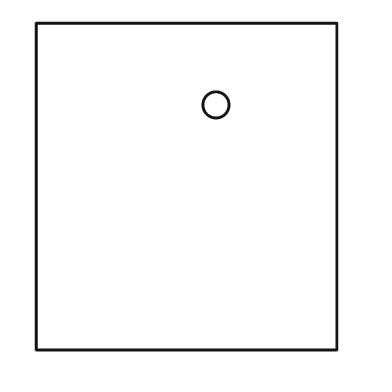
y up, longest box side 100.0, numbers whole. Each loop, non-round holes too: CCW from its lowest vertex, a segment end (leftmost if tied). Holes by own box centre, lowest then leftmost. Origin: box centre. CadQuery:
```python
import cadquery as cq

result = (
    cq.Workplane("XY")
    .moveTo(-46.0, -50.0)
    .lineTo(46.0, -50.0)
    .lineTo(46.0, 50.0)
    .lineTo(-46.0, 50.0)
    .close()
    .moveTo(9.0, 25.0)
    .circle(4.0)
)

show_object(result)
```